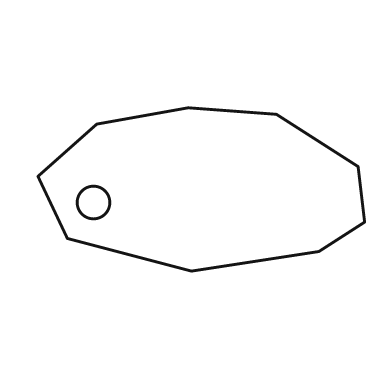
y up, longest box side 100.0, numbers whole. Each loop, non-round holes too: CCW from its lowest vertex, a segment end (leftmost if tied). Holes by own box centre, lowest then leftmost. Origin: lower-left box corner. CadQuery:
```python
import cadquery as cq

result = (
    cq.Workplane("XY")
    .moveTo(47.0, 0.0)
    .lineTo(86.0, 6.0)
    .lineTo(100.0, 15.0)
    .lineTo(98.0, 32.0)
    .lineTo(73.0, 48.0)
    .lineTo(46.0, 50.0)
    .lineTo(18.0, 45.0)
    .lineTo(0.0, 29.0)
    .lineTo(9.0, 10.0)
    .close()
    .moveTo(17.0, 21.0)
    .circle(5.0)
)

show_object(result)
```